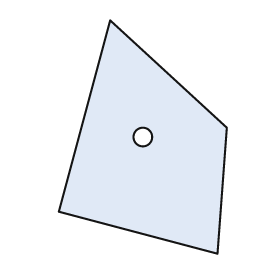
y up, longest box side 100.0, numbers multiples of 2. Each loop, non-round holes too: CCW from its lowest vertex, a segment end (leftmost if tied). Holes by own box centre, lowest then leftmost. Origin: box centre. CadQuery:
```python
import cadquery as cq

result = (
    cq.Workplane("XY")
    .moveTo(32.0, -50.0)
    .lineTo(36.0, 4.0)
    .lineTo(-14.0, 50.0)
    .lineTo(-36.0, -32.0)
    .close()
    .moveTo(0.0, 0.0)
    .circle(4.0)
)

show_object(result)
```